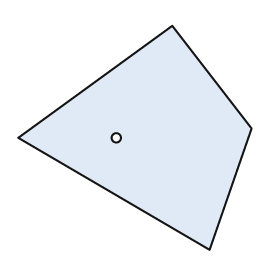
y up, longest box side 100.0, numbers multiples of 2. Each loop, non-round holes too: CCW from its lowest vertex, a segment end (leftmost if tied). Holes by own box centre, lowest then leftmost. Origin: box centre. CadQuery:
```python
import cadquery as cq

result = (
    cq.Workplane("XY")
    .moveTo(32.0, -48.0)
    .lineTo(50.0, 4.0)
    .lineTo(16.0, 48.0)
    .lineTo(-50.0, 0.0)
    .close()
    .moveTo(-8.0, 0.0)
    .circle(2.0)
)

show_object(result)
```